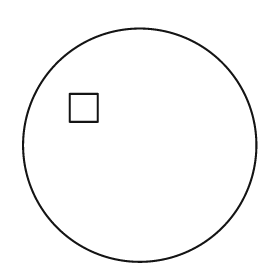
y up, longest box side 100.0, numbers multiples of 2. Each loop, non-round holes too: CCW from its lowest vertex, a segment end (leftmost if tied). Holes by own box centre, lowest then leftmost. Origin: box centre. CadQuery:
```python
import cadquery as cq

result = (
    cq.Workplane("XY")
    .moveTo(0.0, 0.0)
    .circle(50.0)
    .moveTo(-30.0, 10.0)
    .lineTo(-18.0, 10.0)
    .lineTo(-18.0, 22.0)
    .lineTo(-30.0, 22.0)
    .close()
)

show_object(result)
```